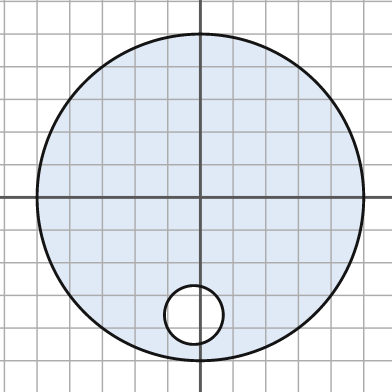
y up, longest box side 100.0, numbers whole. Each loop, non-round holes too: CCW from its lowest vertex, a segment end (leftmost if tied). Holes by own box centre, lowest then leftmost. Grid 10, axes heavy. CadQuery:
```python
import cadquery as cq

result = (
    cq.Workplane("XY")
    .moveTo(0.0, 0.0)
    .circle(50.0)
    .moveTo(-2.0, -36.0)
    .circle(9.0)
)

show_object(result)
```